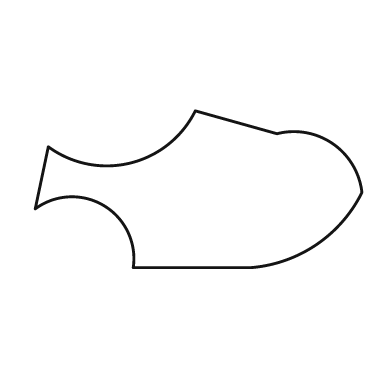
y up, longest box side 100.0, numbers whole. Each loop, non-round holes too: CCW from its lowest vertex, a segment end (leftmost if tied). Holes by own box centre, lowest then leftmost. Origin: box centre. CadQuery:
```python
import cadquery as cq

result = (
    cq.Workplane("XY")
    .moveTo(-20.0, -24.0)
    .lineTo(16.0, -24.0)
    .threePointArc((36.0, -17.0), (50.0, -1.0))
    .threePointArc((41.0, 14.0), (24.0, 17.0))
    .lineTo(-1.0, 24.0)
    .threePointArc((-21.0, 8.0), (-46.0, 13.0))
    .lineTo(-50.0, -6.0)
    .threePointArc((-29.0, -5.0), (-20.0, -24.0))
    .close()
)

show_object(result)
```